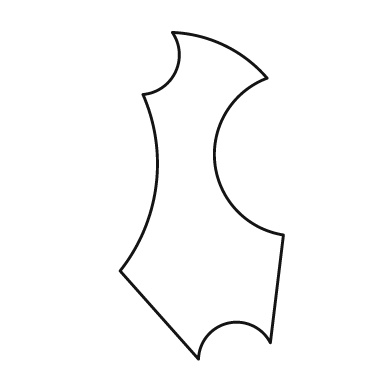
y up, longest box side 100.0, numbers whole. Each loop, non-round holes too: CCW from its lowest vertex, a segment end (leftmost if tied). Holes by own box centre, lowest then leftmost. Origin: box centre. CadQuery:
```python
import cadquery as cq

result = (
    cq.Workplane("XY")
    .moveTo(-1.0, -50.0)
    .threePointArc((8.0, -39.0), (21.0, -45.0))
    .lineTo(25.0, -12.0)
    .threePointArc((4.0, 10.0), (20.0, 36.0))
    .threePointArc((7.0, 46.0), (-9.0, 50.0))
    .threePointArc((-8.0, 38.0), (-18.0, 31.0))
    .threePointArc((-14.0, 3.0), (-25.0, -23.0))
    .close()
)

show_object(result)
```